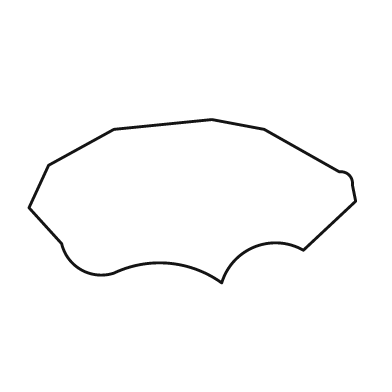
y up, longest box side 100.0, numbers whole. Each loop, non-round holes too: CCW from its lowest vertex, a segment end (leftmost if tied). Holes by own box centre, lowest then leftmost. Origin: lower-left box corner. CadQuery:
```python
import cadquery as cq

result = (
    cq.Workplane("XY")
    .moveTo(59.0, 0.0)
    .threePointArc((69.0, 11.0), (84.0, 10.0))
    .lineTo(100.0, 25.0)
    .lineTo(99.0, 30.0)
    .threePointArc((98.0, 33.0), (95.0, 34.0))
    .lineTo(72.0, 47.0)
    .lineTo(56.0, 50.0)
    .lineTo(26.0, 47.0)
    .lineTo(6.0, 36.0)
    .lineTo(0.0, 23.0)
    .lineTo(10.0, 12.0)
    .threePointArc((16.0, 4.0), (26.0, 3.0))
    .threePointArc((43.0, 6.0), (59.0, 0.0))
    .close()
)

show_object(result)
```